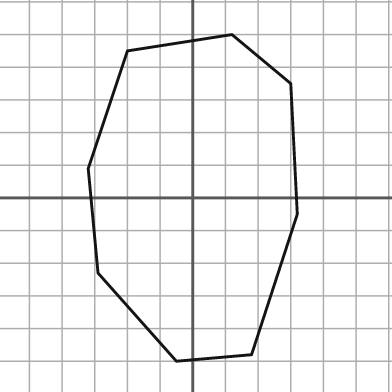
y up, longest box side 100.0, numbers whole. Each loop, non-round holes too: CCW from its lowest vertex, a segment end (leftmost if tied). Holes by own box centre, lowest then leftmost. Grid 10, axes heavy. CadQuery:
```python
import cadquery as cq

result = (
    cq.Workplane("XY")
    .moveTo(-5.0, -50.0)
    .lineTo(18.0, -48.0)
    .lineTo(32.0, -5.0)
    .lineTo(30.0, 35.0)
    .lineTo(12.0, 50.0)
    .lineTo(-20.0, 45.0)
    .lineTo(-32.0, 9.0)
    .lineTo(-29.0, -23.0)
    .close()
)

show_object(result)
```